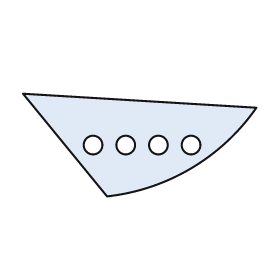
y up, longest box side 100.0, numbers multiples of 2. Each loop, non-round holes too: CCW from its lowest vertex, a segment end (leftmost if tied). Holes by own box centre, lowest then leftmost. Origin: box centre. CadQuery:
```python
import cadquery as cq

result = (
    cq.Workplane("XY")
    .moveTo(-14.0, -22.0)
    .threePointArc((22.0, -10.0), (50.0, 16.0))
    .lineTo(-50.0, 22.0)
    .close()
    .moveTo(-20.0, 0.0)
    .circle(4.0)
    .moveTo(-6.0, 0.0)
    .circle(4.0)
    .moveTo(8.0, 0.0)
    .circle(4.0)
    .moveTo(22.0, 0.0)
    .circle(4.0)
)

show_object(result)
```